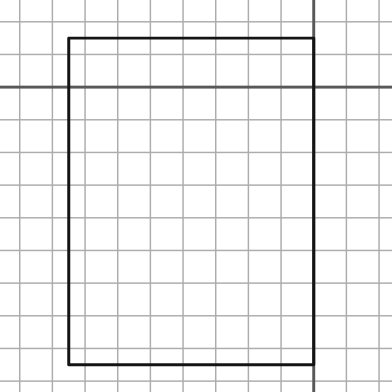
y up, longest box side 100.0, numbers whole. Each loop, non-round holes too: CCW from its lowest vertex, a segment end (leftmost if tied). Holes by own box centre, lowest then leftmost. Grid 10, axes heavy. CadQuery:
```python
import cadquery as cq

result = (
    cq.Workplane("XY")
    .moveTo(-75.0, -85.0)
    .lineTo(0.0, -85.0)
    .lineTo(0.0, 15.0)
    .lineTo(-75.0, 15.0)
    .close()
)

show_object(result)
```